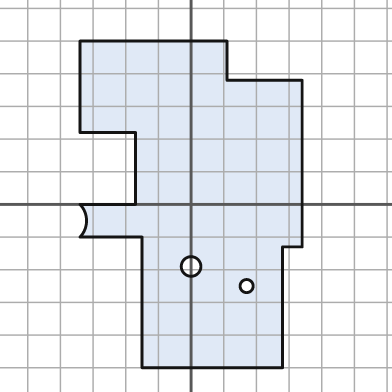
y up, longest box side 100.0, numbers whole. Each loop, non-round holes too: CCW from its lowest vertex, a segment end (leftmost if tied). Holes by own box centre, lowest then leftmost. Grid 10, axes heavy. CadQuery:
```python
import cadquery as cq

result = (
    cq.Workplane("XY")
    .moveTo(-15.0, -50.0)
    .lineTo(28.0, -50.0)
    .lineTo(28.0, -13.0)
    .lineTo(34.0, -13.0)
    .lineTo(34.0, 38.0)
    .lineTo(11.0, 38.0)
    .lineTo(11.0, 50.0)
    .lineTo(-34.0, 50.0)
    .lineTo(-34.0, 22.0)
    .lineTo(-17.0, 22.0)
    .lineTo(-17.0, 0.0)
    .lineTo(-34.0, 0.0)
    .threePointArc((-32.0, -5.0), (-34.0, -10.0))
    .lineTo(-15.0, -10.0)
    .close()
    .moveTo(17.0, -25.0)
    .circle(2.0)
    .moveTo(0.0, -19.0)
    .circle(3.0)
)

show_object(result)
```